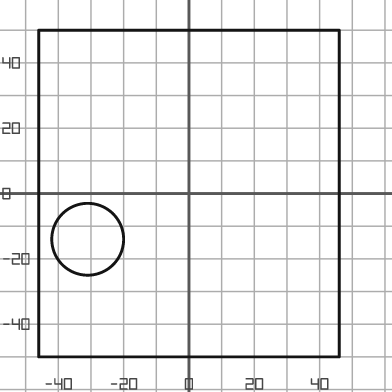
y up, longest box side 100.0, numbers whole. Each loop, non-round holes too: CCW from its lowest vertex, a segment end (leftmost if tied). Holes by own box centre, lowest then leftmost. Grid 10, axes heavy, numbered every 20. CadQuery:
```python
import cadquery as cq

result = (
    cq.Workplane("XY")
    .moveTo(-46.0, -50.0)
    .lineTo(46.0, -50.0)
    .lineTo(46.0, 50.0)
    .lineTo(-46.0, 50.0)
    .close()
    .moveTo(-31.0, -14.0)
    .circle(11.0)
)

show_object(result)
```